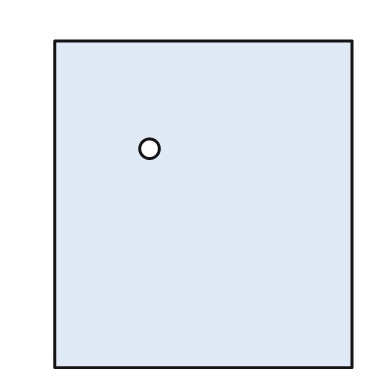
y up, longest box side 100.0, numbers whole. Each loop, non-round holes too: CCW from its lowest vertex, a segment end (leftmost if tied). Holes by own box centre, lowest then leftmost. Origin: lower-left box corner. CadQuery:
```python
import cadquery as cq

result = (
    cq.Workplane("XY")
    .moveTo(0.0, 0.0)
    .lineTo(91.0, 0.0)
    .lineTo(91.0, 100.0)
    .lineTo(0.0, 100.0)
    .close()
    .moveTo(29.0, 67.0)
    .circle(3.0)
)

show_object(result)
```